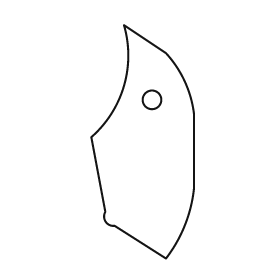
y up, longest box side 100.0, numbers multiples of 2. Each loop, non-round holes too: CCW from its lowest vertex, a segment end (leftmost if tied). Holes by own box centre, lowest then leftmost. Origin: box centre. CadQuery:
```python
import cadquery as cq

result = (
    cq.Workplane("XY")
    .moveTo(10.0, -50.0)
    .threePointArc((18.0, -36.0), (22.0, -20.0))
    .lineTo(22.0, 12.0)
    .threePointArc((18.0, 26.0), (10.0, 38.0))
    .lineTo(-8.0, 50.0)
    .threePointArc((-8.0, 24.0), (-22.0, 2.0))
    .lineTo(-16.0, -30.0)
    .threePointArc((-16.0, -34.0), (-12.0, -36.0))
    .close()
    .moveTo(4.0, 18.0)
    .circle(4.0)
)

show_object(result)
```